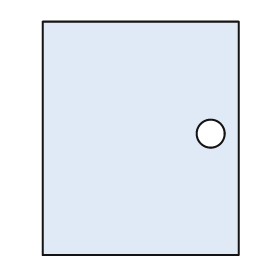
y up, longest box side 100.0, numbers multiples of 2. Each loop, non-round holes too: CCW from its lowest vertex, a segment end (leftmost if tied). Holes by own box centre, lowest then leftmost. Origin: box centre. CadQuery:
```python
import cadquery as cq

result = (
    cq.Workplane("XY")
    .moveTo(-42.0, -50.0)
    .lineTo(42.0, -50.0)
    .lineTo(42.0, 50.0)
    .lineTo(-42.0, 50.0)
    .close()
    .moveTo(30.0, 2.0)
    .circle(6.0)
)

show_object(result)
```